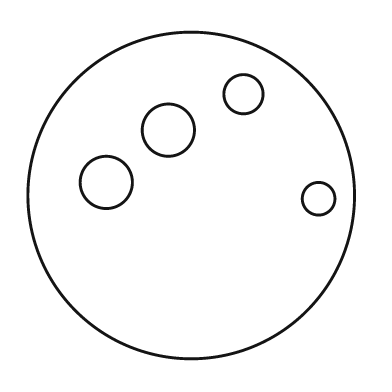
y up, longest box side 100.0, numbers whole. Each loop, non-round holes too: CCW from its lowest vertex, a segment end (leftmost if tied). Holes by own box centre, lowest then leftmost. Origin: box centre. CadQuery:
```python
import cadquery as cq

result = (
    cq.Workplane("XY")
    .moveTo(0.0, 0.0)
    .circle(50.0)
    .moveTo(39.0, -1.0)
    .circle(5.0)
    .moveTo(-26.0, 4.0)
    .circle(8.0)
    .moveTo(-7.0, 20.0)
    .circle(8.0)
    .moveTo(16.0, 31.0)
    .circle(6.0)
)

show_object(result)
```